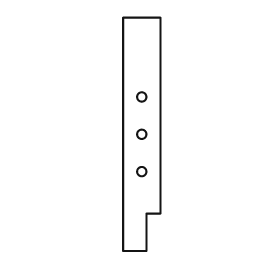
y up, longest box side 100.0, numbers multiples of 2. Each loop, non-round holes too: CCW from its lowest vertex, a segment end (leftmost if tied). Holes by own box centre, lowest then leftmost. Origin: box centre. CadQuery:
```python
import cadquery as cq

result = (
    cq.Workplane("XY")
    .moveTo(-8.0, -50.0)
    .lineTo(2.0, -50.0)
    .lineTo(2.0, -34.0)
    .lineTo(8.0, -34.0)
    .lineTo(8.0, 50.0)
    .lineTo(-8.0, 50.0)
    .close()
    .moveTo(0.0, -16.0)
    .circle(2.0)
    .moveTo(0.0, 0.0)
    .circle(2.0)
    .moveTo(0.0, 16.0)
    .circle(2.0)
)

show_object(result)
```